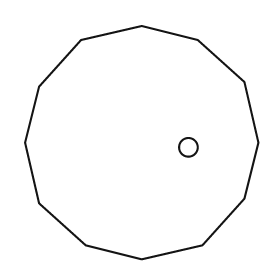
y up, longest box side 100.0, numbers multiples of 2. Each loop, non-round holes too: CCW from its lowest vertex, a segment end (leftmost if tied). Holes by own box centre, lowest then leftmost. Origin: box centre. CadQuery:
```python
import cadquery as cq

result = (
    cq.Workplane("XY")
    .moveTo(0.0, -50.0)
    .lineTo(26.0, -44.0)
    .lineTo(44.0, -24.0)
    .lineTo(50.0, 0.0)
    .lineTo(44.0, 26.0)
    .lineTo(24.0, 44.0)
    .lineTo(0.0, 50.0)
    .lineTo(-26.0, 44.0)
    .lineTo(-44.0, 24.0)
    .lineTo(-50.0, 0.0)
    .lineTo(-44.0, -26.0)
    .lineTo(-24.0, -44.0)
    .close()
    .moveTo(20.0, -2.0)
    .circle(4.0)
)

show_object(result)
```